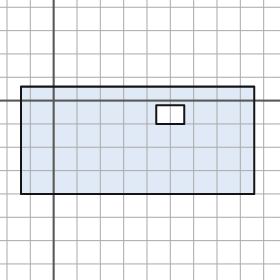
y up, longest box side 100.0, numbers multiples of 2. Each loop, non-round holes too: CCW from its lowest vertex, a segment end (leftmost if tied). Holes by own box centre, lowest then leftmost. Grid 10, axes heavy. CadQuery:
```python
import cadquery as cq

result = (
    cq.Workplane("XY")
    .moveTo(-14.0, -40.0)
    .lineTo(86.0, -40.0)
    .lineTo(86.0, 6.0)
    .lineTo(-14.0, 6.0)
    .close()
    .moveTo(44.0, -10.0)
    .lineTo(56.0, -10.0)
    .lineTo(56.0, -2.0)
    .lineTo(44.0, -2.0)
    .close()
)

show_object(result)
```